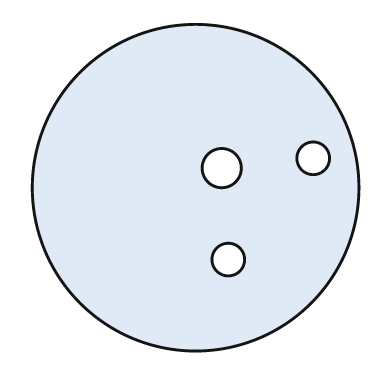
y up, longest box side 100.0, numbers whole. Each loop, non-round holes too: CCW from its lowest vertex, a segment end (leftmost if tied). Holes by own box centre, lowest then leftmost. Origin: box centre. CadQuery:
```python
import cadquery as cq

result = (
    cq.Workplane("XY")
    .moveTo(0.0, 0.0)
    .circle(50.0)
    .moveTo(10.0, -22.0)
    .circle(5.0)
    .moveTo(8.0, 6.0)
    .circle(6.0)
    .moveTo(36.0, 9.0)
    .circle(5.0)
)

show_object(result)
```